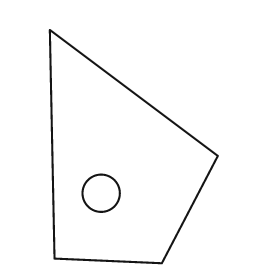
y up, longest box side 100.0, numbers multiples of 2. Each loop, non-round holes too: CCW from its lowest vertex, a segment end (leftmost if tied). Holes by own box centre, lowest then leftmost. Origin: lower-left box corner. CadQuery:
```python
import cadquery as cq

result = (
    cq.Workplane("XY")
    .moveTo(48.0, 0.0)
    .lineTo(72.0, 46.0)
    .lineTo(0.0, 100.0)
    .lineTo(2.0, 2.0)
    .close()
    .moveTo(22.0, 30.0)
    .circle(8.0)
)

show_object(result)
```